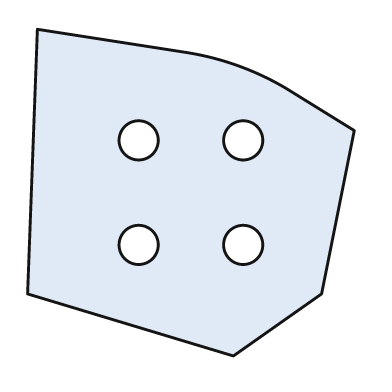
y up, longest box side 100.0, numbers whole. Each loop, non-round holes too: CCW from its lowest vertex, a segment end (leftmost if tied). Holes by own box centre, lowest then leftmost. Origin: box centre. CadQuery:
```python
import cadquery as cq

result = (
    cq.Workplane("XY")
    .moveTo(13.0, -50.0)
    .lineTo(40.0, -31.0)
    .lineTo(50.0, 19.0)
    .lineTo(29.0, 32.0)
    .threePointArc((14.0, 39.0), (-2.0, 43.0))
    .lineTo(-47.0, 50.0)
    .lineTo(-50.0, -31.0)
    .close()
    .moveTo(-16.0, -16.0)
    .circle(6.0)
    .moveTo(16.0, -16.0)
    .circle(6.0)
    .moveTo(-16.0, 16.0)
    .circle(6.0)
    .moveTo(16.0, 16.0)
    .circle(6.0)
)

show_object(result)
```